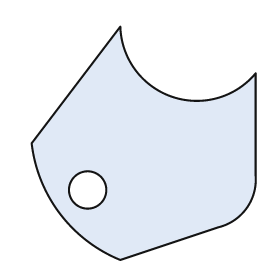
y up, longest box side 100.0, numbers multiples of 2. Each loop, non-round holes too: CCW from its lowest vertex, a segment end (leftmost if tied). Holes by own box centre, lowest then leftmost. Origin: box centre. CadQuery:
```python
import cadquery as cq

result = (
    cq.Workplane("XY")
    .moveTo(-10.0, -50.0)
    .lineTo(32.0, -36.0)
    .threePointArc((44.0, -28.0), (48.0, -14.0))
    .lineTo(48.0, 30.0)
    .threePointArc((12.0, 20.0), (-10.0, 50.0))
    .lineTo(-48.0, 0.0)
    .threePointArc((-36.0, -30.0), (-10.0, -50.0))
    .close()
    .moveTo(-24.0, -20.0)
    .circle(8.0)
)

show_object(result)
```